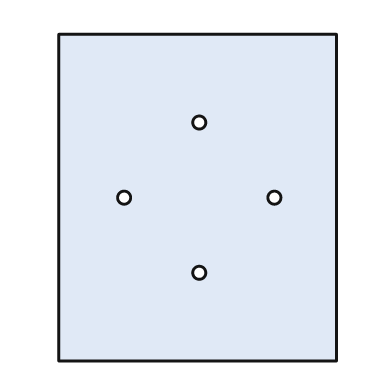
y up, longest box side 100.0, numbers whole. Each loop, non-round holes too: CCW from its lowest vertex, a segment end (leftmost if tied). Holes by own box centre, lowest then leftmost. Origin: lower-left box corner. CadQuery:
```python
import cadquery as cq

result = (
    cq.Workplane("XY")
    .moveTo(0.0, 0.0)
    .lineTo(85.0, 0.0)
    .lineTo(85.0, 100.0)
    .lineTo(0.0, 100.0)
    .close()
    .moveTo(43.0, 27.0)
    .circle(2.0)
    .moveTo(20.0, 50.0)
    .circle(2.0)
    .moveTo(66.0, 50.0)
    .circle(2.0)
    .moveTo(43.0, 73.0)
    .circle(2.0)
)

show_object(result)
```